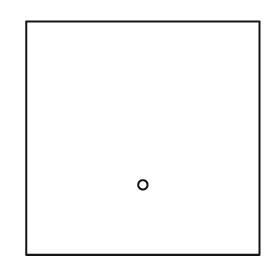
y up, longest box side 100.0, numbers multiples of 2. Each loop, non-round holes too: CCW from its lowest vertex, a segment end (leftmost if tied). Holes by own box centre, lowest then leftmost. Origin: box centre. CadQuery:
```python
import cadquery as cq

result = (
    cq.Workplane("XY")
    .moveTo(-50.0, -50.0)
    .lineTo(50.0, -50.0)
    .lineTo(50.0, 50.0)
    .lineTo(-50.0, 50.0)
    .close()
    .moveTo(0.0, -20.0)
    .circle(2.0)
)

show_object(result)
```